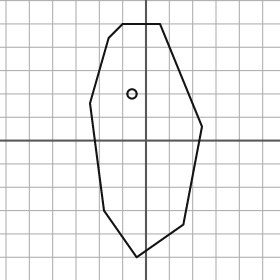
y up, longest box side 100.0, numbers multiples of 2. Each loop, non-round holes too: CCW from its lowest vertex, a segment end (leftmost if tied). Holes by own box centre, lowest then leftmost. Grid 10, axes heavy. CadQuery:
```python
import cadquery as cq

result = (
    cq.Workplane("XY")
    .moveTo(-4.0, -50.0)
    .lineTo(16.0, -36.0)
    .lineTo(24.0, 6.0)
    .lineTo(6.0, 50.0)
    .lineTo(-10.0, 50.0)
    .lineTo(-16.0, 44.0)
    .lineTo(-24.0, 16.0)
    .lineTo(-18.0, -30.0)
    .close()
    .moveTo(-6.0, 20.0)
    .circle(2.0)
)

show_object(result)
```